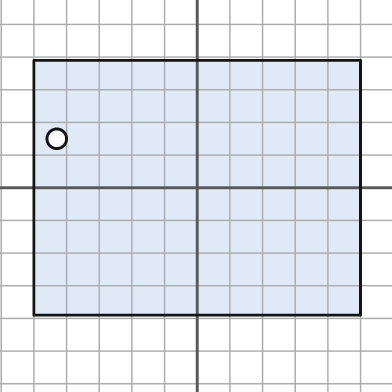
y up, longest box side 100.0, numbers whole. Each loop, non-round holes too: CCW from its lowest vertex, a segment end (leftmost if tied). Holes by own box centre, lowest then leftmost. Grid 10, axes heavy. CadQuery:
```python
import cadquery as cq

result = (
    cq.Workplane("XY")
    .moveTo(-50.0, -39.0)
    .lineTo(50.0, -39.0)
    .lineTo(50.0, 39.0)
    .lineTo(-50.0, 39.0)
    .close()
    .moveTo(-43.0, 15.0)
    .circle(3.0)
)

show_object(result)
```